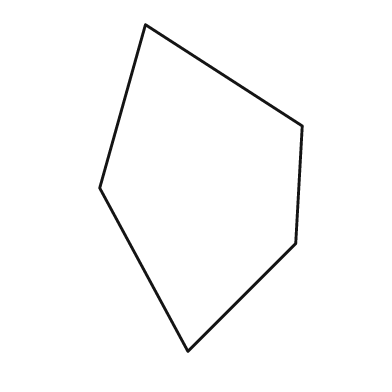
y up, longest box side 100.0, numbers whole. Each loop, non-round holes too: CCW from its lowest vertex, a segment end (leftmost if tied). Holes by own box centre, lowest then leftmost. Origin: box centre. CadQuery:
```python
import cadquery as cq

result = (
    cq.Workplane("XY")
    .moveTo(-4.0, -50.0)
    .lineTo(29.0, -17.0)
    .lineTo(31.0, 19.0)
    .lineTo(-17.0, 50.0)
    .lineTo(-31.0, 0.0)
    .close()
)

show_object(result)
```